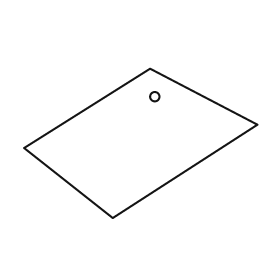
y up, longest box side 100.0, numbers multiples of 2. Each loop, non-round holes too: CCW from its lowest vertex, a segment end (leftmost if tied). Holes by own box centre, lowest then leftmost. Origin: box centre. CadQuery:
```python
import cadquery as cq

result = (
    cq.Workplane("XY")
    .moveTo(-12.0, -32.0)
    .lineTo(50.0, 8.0)
    .lineTo(4.0, 32.0)
    .lineTo(-50.0, -2.0)
    .close()
    .moveTo(6.0, 20.0)
    .circle(2.0)
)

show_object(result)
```